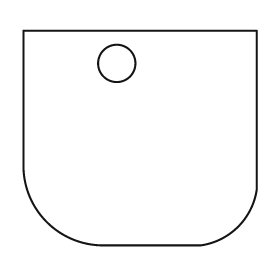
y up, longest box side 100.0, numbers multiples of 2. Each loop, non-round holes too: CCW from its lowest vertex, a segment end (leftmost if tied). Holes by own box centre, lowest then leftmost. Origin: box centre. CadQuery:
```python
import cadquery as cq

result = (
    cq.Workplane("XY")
    .moveTo(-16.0, -46.0)
    .lineTo(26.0, -46.0)
    .threePointArc((42.0, -38.0), (50.0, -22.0))
    .lineTo(50.0, 46.0)
    .lineTo(-50.0, 46.0)
    .lineTo(-50.0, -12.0)
    .threePointArc((-40.0, -36.0), (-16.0, -46.0))
    .close()
    .moveTo(-10.0, 32.0)
    .circle(8.0)
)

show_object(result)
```